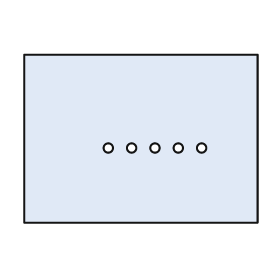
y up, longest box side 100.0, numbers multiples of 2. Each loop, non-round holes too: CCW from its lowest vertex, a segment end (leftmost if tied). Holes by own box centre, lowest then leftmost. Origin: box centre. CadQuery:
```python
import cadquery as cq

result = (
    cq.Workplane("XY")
    .moveTo(-50.0, -36.0)
    .lineTo(50.0, -36.0)
    .lineTo(50.0, 36.0)
    .lineTo(-50.0, 36.0)
    .close()
    .moveTo(-14.0, -4.0)
    .circle(2.0)
    .moveTo(-4.0, -4.0)
    .circle(2.0)
    .moveTo(6.0, -4.0)
    .circle(2.0)
    .moveTo(16.0, -4.0)
    .circle(2.0)
    .moveTo(26.0, -4.0)
    .circle(2.0)
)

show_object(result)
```